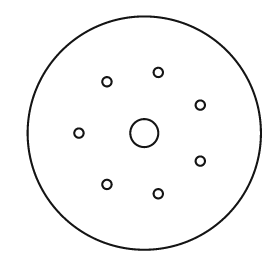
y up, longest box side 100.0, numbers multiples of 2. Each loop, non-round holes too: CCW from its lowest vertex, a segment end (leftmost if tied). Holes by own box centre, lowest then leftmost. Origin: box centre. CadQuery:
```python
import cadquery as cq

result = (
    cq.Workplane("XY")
    .moveTo(0.0, 0.0)
    .circle(50.0)
    .moveTo(6.0, -26.0)
    .circle(2.0)
    .moveTo(-16.0, -22.0)
    .circle(2.0)
    .moveTo(24.0, -12.0)
    .circle(2.0)
    .moveTo(-28.0, 0.0)
    .circle(2.0)
    .moveTo(0.0, 0.0)
    .circle(6.0)
    .moveTo(24.0, 12.0)
    .circle(2.0)
    .moveTo(-16.0, 22.0)
    .circle(2.0)
    .moveTo(6.0, 26.0)
    .circle(2.0)
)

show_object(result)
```